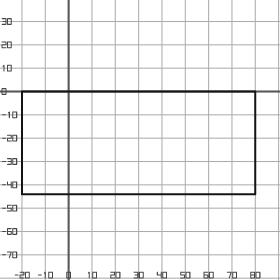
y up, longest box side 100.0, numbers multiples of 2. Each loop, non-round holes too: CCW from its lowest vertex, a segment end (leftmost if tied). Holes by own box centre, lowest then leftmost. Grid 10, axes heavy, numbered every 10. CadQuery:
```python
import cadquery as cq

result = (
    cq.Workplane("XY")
    .moveTo(-20.0, -44.0)
    .lineTo(80.0, -44.0)
    .lineTo(80.0, 0.0)
    .lineTo(-20.0, 0.0)
    .close()
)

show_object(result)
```